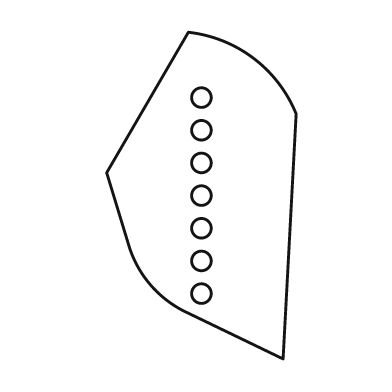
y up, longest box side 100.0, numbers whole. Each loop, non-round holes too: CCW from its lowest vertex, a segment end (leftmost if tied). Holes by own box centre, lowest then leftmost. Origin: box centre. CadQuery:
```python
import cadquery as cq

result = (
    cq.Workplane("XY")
    .moveTo(25.0, -50.0)
    .lineTo(29.0, 25.0)
    .threePointArc((16.0, 42.0), (-4.0, 50.0))
    .lineTo(-29.0, 7.0)
    .lineTo(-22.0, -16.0)
    .threePointArc((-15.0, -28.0), (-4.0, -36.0))
    .close()
    .moveTo(0.0, -30.0)
    .circle(3.0)
    .moveTo(0.0, -20.0)
    .circle(3.0)
    .moveTo(0.0, -10.0)
    .circle(3.0)
    .moveTo(0.0, 0.0)
    .circle(3.0)
    .moveTo(0.0, 10.0)
    .circle(3.0)
    .moveTo(0.0, 20.0)
    .circle(3.0)
    .moveTo(0.0, 30.0)
    .circle(3.0)
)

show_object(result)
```